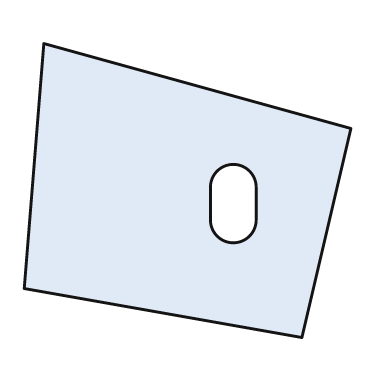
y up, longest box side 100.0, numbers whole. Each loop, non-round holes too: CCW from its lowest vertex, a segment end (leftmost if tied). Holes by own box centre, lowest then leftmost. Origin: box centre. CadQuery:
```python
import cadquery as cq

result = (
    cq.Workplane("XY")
    .moveTo(35.0, -45.0)
    .lineTo(50.0, 19.0)
    .lineTo(-44.0, 45.0)
    .lineTo(-50.0, -30.0)
    .close()
    .moveTo(7.0, -9.0)
    .threePointArc((14.0, -16.0), (21.0, -9.0))
    .lineTo(21.0, 1.0)
    .threePointArc((14.0, 8.0), (7.0, 1.0))
    .close()
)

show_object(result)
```